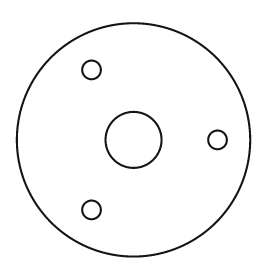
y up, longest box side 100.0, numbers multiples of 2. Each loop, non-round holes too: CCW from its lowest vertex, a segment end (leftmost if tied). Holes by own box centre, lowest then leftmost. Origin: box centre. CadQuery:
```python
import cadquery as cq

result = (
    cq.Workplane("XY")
    .moveTo(0.0, 0.0)
    .circle(50.0)
    .moveTo(-18.0, -30.0)
    .circle(4.0)
    .moveTo(0.0, 0.0)
    .circle(12.0)
    .moveTo(36.0, 0.0)
    .circle(4.0)
    .moveTo(-18.0, 30.0)
    .circle(4.0)
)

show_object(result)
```